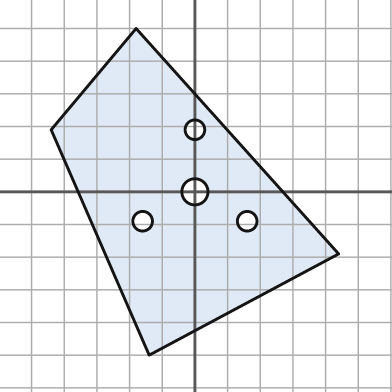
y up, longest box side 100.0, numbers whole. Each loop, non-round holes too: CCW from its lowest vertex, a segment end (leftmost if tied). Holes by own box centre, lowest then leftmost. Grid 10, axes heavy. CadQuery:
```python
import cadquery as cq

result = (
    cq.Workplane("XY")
    .moveTo(-14.0, -50.0)
    .lineTo(44.0, -19.0)
    .lineTo(-18.0, 50.0)
    .lineTo(-44.0, 19.0)
    .close()
    .moveTo(-16.0, -9.0)
    .circle(3.0)
    .moveTo(16.0, -9.0)
    .circle(3.0)
    .moveTo(0.0, 0.0)
    .circle(4.0)
    .moveTo(0.0, 19.0)
    .circle(3.0)
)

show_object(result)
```